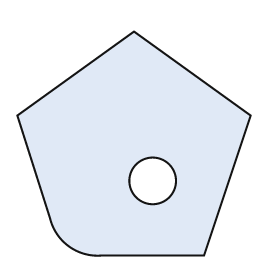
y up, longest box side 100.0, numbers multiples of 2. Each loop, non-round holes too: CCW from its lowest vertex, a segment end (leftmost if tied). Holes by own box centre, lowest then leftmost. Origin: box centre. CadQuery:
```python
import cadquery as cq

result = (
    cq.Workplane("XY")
    .moveTo(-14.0, -48.0)
    .lineTo(30.0, -48.0)
    .lineTo(50.0, 12.0)
    .lineTo(0.0, 48.0)
    .lineTo(-50.0, 12.0)
    .lineTo(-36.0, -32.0)
    .threePointArc((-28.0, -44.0), (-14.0, -48.0))
    .close()
    .moveTo(8.0, -16.0)
    .circle(10.0)
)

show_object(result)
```